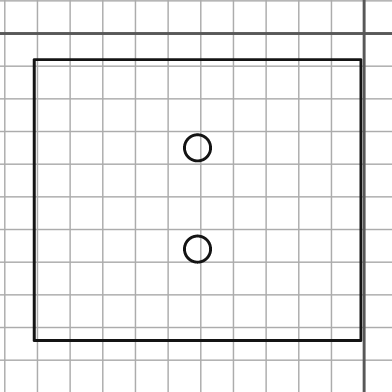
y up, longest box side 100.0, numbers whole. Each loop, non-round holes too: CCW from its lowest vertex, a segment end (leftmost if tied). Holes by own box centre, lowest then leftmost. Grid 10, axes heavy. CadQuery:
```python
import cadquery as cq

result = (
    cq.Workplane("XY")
    .moveTo(-101.0, -94.0)
    .lineTo(-1.0, -94.0)
    .lineTo(-1.0, -8.0)
    .lineTo(-101.0, -8.0)
    .close()
    .moveTo(-51.0, -66.0)
    .circle(4.0)
    .moveTo(-51.0, -35.0)
    .circle(4.0)
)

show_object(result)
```